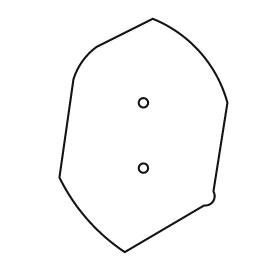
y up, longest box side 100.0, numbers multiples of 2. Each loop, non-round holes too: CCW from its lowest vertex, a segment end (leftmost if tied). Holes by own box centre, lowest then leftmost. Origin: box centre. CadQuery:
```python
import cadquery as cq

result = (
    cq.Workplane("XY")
    .moveTo(-8.0, -50.0)
    .lineTo(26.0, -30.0)
    .threePointArc((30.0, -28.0), (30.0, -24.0))
    .lineTo(36.0, 14.0)
    .threePointArc((24.0, 36.0), (4.0, 50.0))
    .lineTo(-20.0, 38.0)
    .threePointArc((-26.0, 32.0), (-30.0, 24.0))
    .lineTo(-36.0, -18.0)
    .threePointArc((-24.0, -36.0), (-8.0, -50.0))
    .close()
    .moveTo(0.0, -14.0)
    .circle(2.0)
    .moveTo(0.0, 14.0)
    .circle(2.0)
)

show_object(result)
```